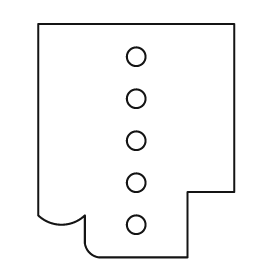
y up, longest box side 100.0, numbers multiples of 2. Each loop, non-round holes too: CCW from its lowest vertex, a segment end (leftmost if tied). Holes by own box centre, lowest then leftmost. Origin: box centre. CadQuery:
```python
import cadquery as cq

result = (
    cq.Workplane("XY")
    .moveTo(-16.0, -50.0)
    .lineTo(22.0, -50.0)
    .lineTo(22.0, -22.0)
    .lineTo(42.0, -22.0)
    .lineTo(42.0, 50.0)
    .lineTo(-42.0, 50.0)
    .lineTo(-42.0, -32.0)
    .threePointArc((-32.0, -36.0), (-22.0, -32.0))
    .lineTo(-22.0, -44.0)
    .threePointArc((-20.0, -48.0), (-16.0, -50.0))
    .close()
    .moveTo(0.0, -36.0)
    .circle(4.0)
    .moveTo(0.0, -18.0)
    .circle(4.0)
    .moveTo(0.0, 0.0)
    .circle(4.0)
    .moveTo(0.0, 18.0)
    .circle(4.0)
    .moveTo(0.0, 36.0)
    .circle(4.0)
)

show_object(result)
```